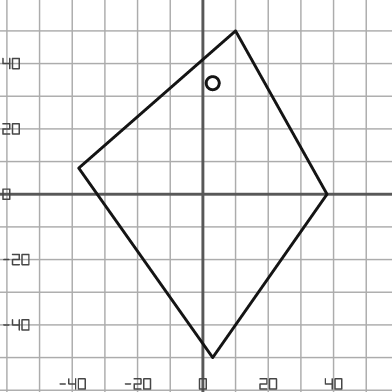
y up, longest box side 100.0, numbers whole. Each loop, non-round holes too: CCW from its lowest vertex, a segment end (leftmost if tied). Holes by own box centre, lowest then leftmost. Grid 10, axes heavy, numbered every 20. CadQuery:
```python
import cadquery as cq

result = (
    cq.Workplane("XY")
    .moveTo(3.0, -50.0)
    .lineTo(38.0, 0.0)
    .lineTo(10.0, 50.0)
    .lineTo(-38.0, 8.0)
    .close()
    .moveTo(3.0, 34.0)
    .circle(2.0)
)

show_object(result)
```